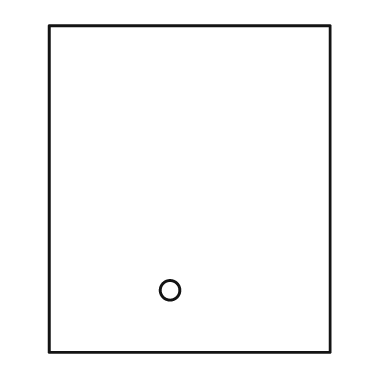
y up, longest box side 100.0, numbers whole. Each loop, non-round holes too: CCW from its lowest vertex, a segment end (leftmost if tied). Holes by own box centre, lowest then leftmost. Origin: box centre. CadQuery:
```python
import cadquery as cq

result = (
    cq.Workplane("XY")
    .moveTo(-43.0, -50.0)
    .lineTo(43.0, -50.0)
    .lineTo(43.0, 50.0)
    .lineTo(-43.0, 50.0)
    .close()
    .moveTo(-6.0, -31.0)
    .circle(3.0)
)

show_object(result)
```